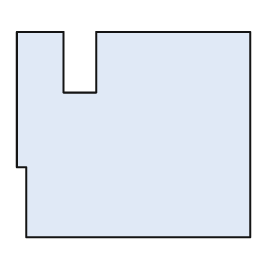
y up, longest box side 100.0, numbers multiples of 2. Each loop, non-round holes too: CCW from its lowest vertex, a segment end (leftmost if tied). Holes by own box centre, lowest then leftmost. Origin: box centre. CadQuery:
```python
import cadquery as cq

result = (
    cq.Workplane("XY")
    .moveTo(-46.0, -44.0)
    .lineTo(50.0, -44.0)
    .lineTo(50.0, 44.0)
    .lineTo(-16.0, 44.0)
    .lineTo(-16.0, 18.0)
    .lineTo(-30.0, 18.0)
    .lineTo(-30.0, 44.0)
    .lineTo(-50.0, 44.0)
    .lineTo(-50.0, -14.0)
    .lineTo(-46.0, -14.0)
    .close()
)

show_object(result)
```